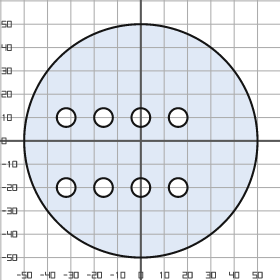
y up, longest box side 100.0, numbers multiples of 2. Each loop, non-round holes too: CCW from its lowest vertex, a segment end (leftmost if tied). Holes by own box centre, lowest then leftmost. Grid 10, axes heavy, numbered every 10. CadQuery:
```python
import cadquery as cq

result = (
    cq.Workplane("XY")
    .moveTo(0.0, 0.0)
    .circle(50.0)
    .moveTo(-32.0, -20.0)
    .circle(4.0)
    .moveTo(-16.0, -20.0)
    .circle(4.0)
    .moveTo(0.0, -20.0)
    .circle(4.0)
    .moveTo(16.0, -20.0)
    .circle(4.0)
    .moveTo(-32.0, 10.0)
    .circle(4.0)
    .moveTo(-16.0, 10.0)
    .circle(4.0)
    .moveTo(0.0, 10.0)
    .circle(4.0)
    .moveTo(16.0, 10.0)
    .circle(4.0)
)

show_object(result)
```